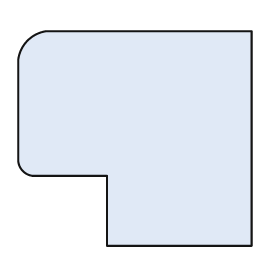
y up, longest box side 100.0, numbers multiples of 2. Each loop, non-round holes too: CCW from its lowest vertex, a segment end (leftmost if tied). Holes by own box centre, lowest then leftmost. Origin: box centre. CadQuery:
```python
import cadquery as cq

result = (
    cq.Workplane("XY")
    .moveTo(-12.0, -46.0)
    .lineTo(50.0, -46.0)
    .lineTo(50.0, 46.0)
    .lineTo(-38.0, 46.0)
    .threePointArc((-46.0, 42.0), (-50.0, 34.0))
    .lineTo(-50.0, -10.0)
    .threePointArc((-48.0, -14.0), (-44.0, -16.0))
    .lineTo(-12.0, -16.0)
    .close()
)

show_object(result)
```